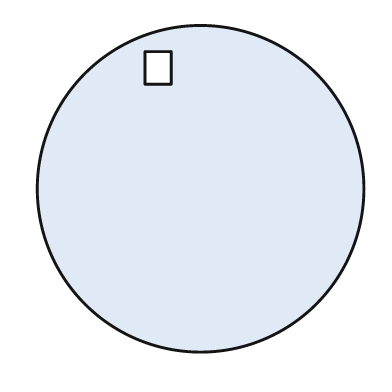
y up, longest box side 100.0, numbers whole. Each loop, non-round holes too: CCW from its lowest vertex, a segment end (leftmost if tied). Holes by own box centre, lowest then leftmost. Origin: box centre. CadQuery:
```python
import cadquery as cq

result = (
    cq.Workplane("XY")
    .moveTo(0.0, 0.0)
    .circle(50.0)
    .moveTo(-17.0, 32.0)
    .lineTo(-9.0, 32.0)
    .lineTo(-9.0, 42.0)
    .lineTo(-17.0, 42.0)
    .close()
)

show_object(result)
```